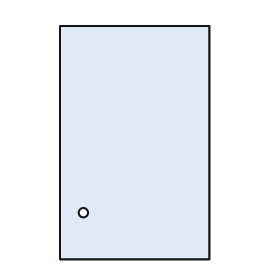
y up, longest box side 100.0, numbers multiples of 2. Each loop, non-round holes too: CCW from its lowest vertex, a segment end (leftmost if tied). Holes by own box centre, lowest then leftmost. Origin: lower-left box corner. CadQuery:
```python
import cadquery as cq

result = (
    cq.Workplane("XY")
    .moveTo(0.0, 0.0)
    .lineTo(64.0, 0.0)
    .lineTo(64.0, 100.0)
    .lineTo(0.0, 100.0)
    .close()
    .moveTo(10.0, 20.0)
    .circle(2.0)
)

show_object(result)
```